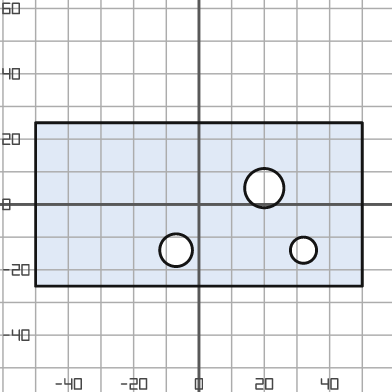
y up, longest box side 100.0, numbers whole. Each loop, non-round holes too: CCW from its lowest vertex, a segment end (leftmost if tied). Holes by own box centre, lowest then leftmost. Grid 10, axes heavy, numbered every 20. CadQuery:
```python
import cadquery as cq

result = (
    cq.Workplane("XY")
    .moveTo(-50.0, -25.0)
    .lineTo(50.0, -25.0)
    .lineTo(50.0, 25.0)
    .lineTo(-50.0, 25.0)
    .close()
    .moveTo(-7.0, -14.0)
    .circle(5.0)
    .moveTo(32.0, -14.0)
    .circle(4.0)
    .moveTo(20.0, 5.0)
    .circle(6.0)
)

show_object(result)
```